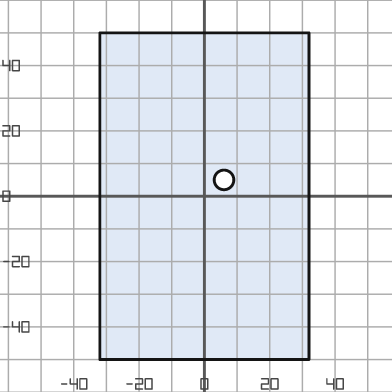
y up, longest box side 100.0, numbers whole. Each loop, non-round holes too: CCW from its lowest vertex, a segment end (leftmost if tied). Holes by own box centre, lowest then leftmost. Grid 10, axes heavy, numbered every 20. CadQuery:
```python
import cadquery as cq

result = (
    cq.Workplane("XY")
    .moveTo(-32.0, -50.0)
    .lineTo(32.0, -50.0)
    .lineTo(32.0, 50.0)
    .lineTo(-32.0, 50.0)
    .close()
    .moveTo(6.0, 5.0)
    .circle(3.0)
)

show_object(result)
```